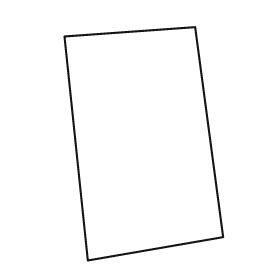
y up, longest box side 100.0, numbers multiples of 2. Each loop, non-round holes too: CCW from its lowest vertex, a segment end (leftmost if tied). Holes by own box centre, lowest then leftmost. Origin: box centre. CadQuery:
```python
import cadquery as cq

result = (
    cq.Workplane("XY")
    .moveTo(-24.0, -50.0)
    .lineTo(34.0, -40.0)
    .lineTo(22.0, 50.0)
    .lineTo(-34.0, 46.0)
    .close()
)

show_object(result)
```